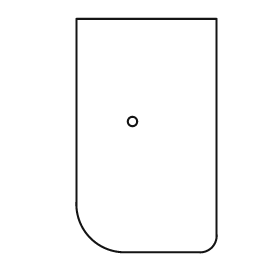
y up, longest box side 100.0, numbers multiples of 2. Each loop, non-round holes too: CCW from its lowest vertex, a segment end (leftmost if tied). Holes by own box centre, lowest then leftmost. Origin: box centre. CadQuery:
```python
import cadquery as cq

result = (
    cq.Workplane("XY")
    .moveTo(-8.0, -50.0)
    .lineTo(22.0, -50.0)
    .threePointArc((28.0, -48.0), (30.0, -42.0))
    .lineTo(30.0, 50.0)
    .lineTo(-30.0, 50.0)
    .lineTo(-30.0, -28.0)
    .threePointArc((-24.0, -44.0), (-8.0, -50.0))
    .close()
    .moveTo(-6.0, 6.0)
    .circle(2.0)
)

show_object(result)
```